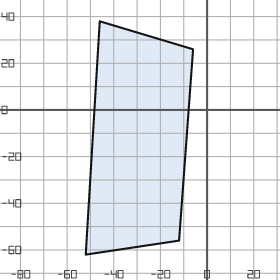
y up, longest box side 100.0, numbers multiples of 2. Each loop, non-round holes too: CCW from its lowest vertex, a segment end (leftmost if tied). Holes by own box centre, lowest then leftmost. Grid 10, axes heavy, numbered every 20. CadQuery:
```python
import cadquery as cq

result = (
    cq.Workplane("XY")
    .moveTo(-52.0, -62.0)
    .lineTo(-12.0, -56.0)
    .lineTo(-6.0, 26.0)
    .lineTo(-46.0, 38.0)
    .close()
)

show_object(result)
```